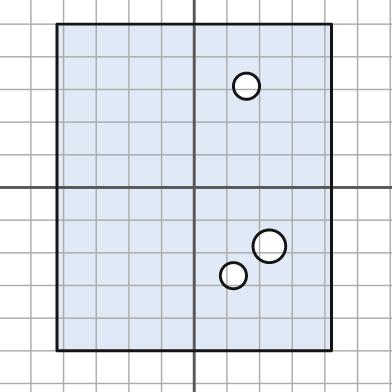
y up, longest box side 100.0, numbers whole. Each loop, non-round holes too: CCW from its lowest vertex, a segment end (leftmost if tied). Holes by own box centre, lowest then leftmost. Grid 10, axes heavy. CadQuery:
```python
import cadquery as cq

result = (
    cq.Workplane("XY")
    .moveTo(-42.0, -50.0)
    .lineTo(42.0, -50.0)
    .lineTo(42.0, 50.0)
    .lineTo(-42.0, 50.0)
    .close()
    .moveTo(12.0, -27.0)
    .circle(4.0)
    .moveTo(23.0, -18.0)
    .circle(5.0)
    .moveTo(16.0, 31.0)
    .circle(4.0)
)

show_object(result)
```